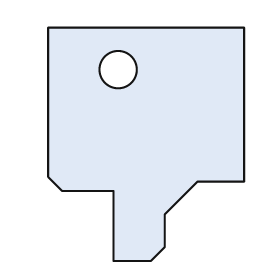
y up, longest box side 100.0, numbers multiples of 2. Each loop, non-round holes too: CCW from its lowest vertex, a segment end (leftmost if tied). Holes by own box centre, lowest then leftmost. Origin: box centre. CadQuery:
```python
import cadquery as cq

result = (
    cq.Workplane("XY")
    .moveTo(-14.0, -50.0)
    .lineTo(2.0, -50.0)
    .lineTo(8.0, -44.0)
    .lineTo(8.0, -30.0)
    .lineTo(22.0, -16.0)
    .lineTo(42.0, -16.0)
    .lineTo(42.0, 50.0)
    .lineTo(-42.0, 50.0)
    .lineTo(-42.0, -14.0)
    .lineTo(-36.0, -20.0)
    .lineTo(-14.0, -20.0)
    .close()
    .moveTo(-12.0, 32.0)
    .circle(8.0)
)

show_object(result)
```